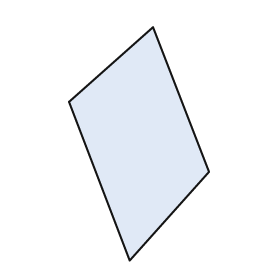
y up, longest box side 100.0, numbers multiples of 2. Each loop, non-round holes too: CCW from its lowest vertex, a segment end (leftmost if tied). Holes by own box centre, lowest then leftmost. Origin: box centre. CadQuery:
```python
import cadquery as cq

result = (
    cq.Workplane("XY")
    .moveTo(-4.0, -50.0)
    .lineTo(30.0, -12.0)
    .lineTo(6.0, 50.0)
    .lineTo(-30.0, 18.0)
    .close()
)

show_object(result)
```